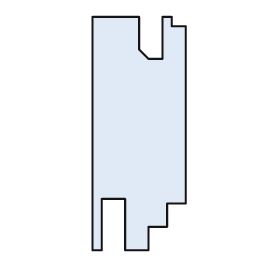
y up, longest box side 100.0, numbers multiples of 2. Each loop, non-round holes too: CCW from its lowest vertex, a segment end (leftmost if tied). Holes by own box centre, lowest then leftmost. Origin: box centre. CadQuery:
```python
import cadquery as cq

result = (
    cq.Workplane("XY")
    .moveTo(-20.0, -50.0)
    .lineTo(-16.0, -50.0)
    .lineTo(-16.0, -28.0)
    .lineTo(-6.0, -28.0)
    .lineTo(-6.0, -50.0)
    .lineTo(4.0, -50.0)
    .lineTo(4.0, -40.0)
    .lineTo(12.0, -40.0)
    .lineTo(12.0, -30.0)
    .lineTo(20.0, -30.0)
    .lineTo(20.0, 46.0)
    .lineTo(14.0, 46.0)
    .lineTo(14.0, 50.0)
    .lineTo(10.0, 50.0)
    .lineTo(10.0, 32.0)
    .lineTo(4.0, 32.0)
    .lineTo(0.0, 36.0)
    .lineTo(0.0, 50.0)
    .lineTo(-20.0, 50.0)
    .close()
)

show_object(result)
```